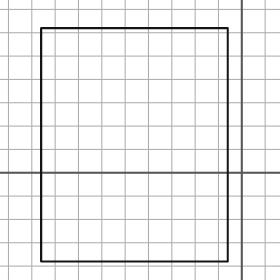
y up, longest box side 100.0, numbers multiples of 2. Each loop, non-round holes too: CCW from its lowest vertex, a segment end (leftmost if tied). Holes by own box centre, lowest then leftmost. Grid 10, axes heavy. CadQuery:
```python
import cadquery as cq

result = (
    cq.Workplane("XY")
    .moveTo(-86.0, -38.0)
    .lineTo(-6.0, -38.0)
    .lineTo(-6.0, 62.0)
    .lineTo(-86.0, 62.0)
    .close()
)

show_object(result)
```